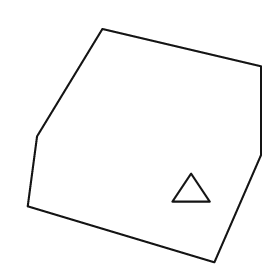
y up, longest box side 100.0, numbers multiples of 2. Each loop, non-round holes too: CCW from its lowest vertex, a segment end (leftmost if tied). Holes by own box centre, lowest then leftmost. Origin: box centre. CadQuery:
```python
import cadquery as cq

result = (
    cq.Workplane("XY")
    .moveTo(30.0, -50.0)
    .lineTo(50.0, -4.0)
    .lineTo(50.0, 34.0)
    .lineTo(-18.0, 50.0)
    .lineTo(-46.0, 4.0)
    .lineTo(-50.0, -26.0)
    .close()
    .moveTo(12.0, -24.0)
    .lineTo(28.0, -24.0)
    .lineTo(20.0, -12.0)
    .close()
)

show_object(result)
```